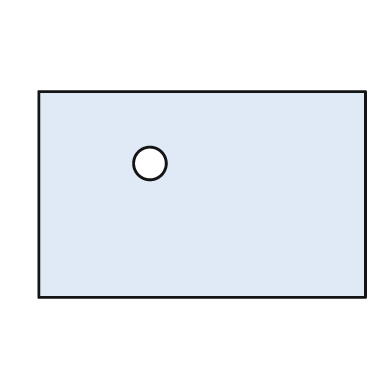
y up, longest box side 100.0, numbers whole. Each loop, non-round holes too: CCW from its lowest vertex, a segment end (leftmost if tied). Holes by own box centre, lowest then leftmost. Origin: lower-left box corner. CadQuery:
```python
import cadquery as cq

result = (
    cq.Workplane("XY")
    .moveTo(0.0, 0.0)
    .lineTo(100.0, 0.0)
    .lineTo(100.0, 63.0)
    .lineTo(0.0, 63.0)
    .close()
    .moveTo(34.0, 41.0)
    .circle(5.0)
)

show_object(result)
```